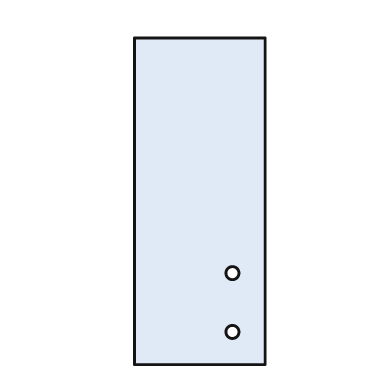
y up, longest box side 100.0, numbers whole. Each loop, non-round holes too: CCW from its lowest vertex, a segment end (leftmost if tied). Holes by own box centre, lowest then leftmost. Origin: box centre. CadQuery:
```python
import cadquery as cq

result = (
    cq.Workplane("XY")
    .moveTo(-20.0, -50.0)
    .lineTo(20.0, -50.0)
    .lineTo(20.0, 50.0)
    .lineTo(-20.0, 50.0)
    .close()
    .moveTo(10.0, -40.0)
    .circle(2.0)
    .moveTo(10.0, -22.0)
    .circle(2.0)
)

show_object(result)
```